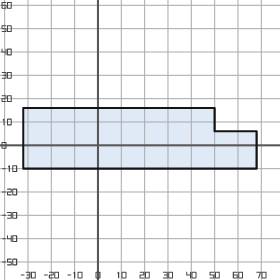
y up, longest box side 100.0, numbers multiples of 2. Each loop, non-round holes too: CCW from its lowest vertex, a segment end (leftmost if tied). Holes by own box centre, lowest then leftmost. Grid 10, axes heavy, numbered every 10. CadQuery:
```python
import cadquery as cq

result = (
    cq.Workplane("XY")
    .moveTo(-32.0, -10.0)
    .lineTo(68.0, -10.0)
    .lineTo(68.0, 6.0)
    .lineTo(50.0, 6.0)
    .lineTo(50.0, 16.0)
    .lineTo(-32.0, 16.0)
    .close()
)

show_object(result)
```